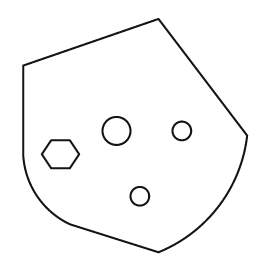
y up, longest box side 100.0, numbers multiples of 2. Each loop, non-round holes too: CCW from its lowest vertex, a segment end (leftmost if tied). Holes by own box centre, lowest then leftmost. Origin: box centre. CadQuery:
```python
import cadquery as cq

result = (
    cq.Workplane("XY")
    .moveTo(10.0, -50.0)
    .threePointArc((36.0, -30.0), (48.0, 0.0))
    .lineTo(10.0, 50.0)
    .lineTo(-48.0, 30.0)
    .lineTo(-48.0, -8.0)
    .threePointArc((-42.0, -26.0), (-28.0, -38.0))
    .close()
    .moveTo(2.0, -26.0)
    .circle(4.0)
    .moveTo(-36.0, -14.0)
    .lineTo(-28.0, -14.0)
    .lineTo(-24.0, -8.0)
    .lineTo(-28.0, -2.0)
    .lineTo(-36.0, -2.0)
    .lineTo(-40.0, -8.0)
    .close()
    .moveTo(-8.0, 2.0)
    .circle(6.0)
    .moveTo(20.0, 2.0)
    .circle(4.0)
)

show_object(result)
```